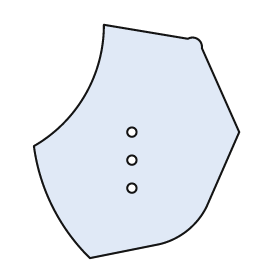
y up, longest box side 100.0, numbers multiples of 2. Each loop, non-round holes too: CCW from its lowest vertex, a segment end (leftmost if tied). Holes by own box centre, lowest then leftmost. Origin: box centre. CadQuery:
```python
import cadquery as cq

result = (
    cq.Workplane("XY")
    .moveTo(-20.0, -50.0)
    .lineTo(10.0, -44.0)
    .threePointArc((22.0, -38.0), (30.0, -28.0))
    .lineTo(44.0, 4.0)
    .lineTo(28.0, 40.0)
    .threePointArc((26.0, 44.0), (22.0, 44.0))
    .lineTo(-14.0, 50.0)
    .threePointArc((-22.0, 20.0), (-44.0, -2.0))
    .threePointArc((-36.0, -28.0), (-20.0, -50.0))
    .close()
    .moveTo(-2.0, -20.0)
    .circle(2.0)
    .moveTo(-2.0, -8.0)
    .circle(2.0)
    .moveTo(-2.0, 4.0)
    .circle(2.0)
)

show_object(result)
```